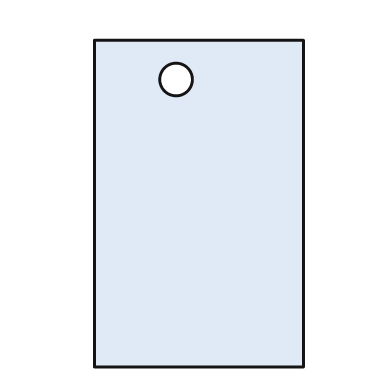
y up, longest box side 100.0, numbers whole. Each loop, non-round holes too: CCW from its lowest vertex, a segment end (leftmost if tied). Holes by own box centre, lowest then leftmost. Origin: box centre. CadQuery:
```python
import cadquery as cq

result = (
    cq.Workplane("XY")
    .moveTo(-32.0, -50.0)
    .lineTo(32.0, -50.0)
    .lineTo(32.0, 50.0)
    .lineTo(-32.0, 50.0)
    .close()
    .moveTo(-7.0, 38.0)
    .circle(5.0)
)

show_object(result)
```